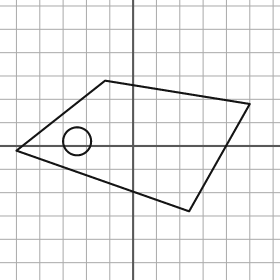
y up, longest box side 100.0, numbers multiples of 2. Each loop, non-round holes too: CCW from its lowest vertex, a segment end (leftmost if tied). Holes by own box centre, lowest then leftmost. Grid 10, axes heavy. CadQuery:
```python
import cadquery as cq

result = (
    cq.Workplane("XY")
    .moveTo(24.0, -28.0)
    .lineTo(50.0, 18.0)
    .lineTo(-12.0, 28.0)
    .lineTo(-50.0, -2.0)
    .close()
    .moveTo(-24.0, 2.0)
    .circle(6.0)
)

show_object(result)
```